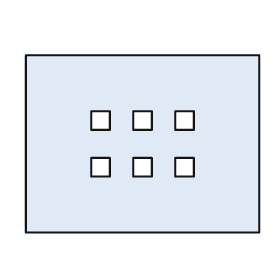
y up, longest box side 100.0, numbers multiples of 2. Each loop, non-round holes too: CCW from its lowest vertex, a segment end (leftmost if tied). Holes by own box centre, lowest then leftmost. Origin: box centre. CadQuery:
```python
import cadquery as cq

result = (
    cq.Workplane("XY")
    .moveTo(-50.0, -38.0)
    .lineTo(50.0, -38.0)
    .lineTo(50.0, 38.0)
    .lineTo(-50.0, 38.0)
    .close()
    .moveTo(-22.0, -14.0)
    .lineTo(-14.0, -14.0)
    .lineTo(-14.0, -6.0)
    .lineTo(-22.0, -6.0)
    .close()
    .moveTo(-4.0, -14.0)
    .lineTo(4.0, -14.0)
    .lineTo(4.0, -6.0)
    .lineTo(-4.0, -6.0)
    .close()
    .moveTo(14.0, -14.0)
    .lineTo(22.0, -14.0)
    .lineTo(22.0, -6.0)
    .lineTo(14.0, -6.0)
    .close()
    .moveTo(-22.0, 6.0)
    .lineTo(-14.0, 6.0)
    .lineTo(-14.0, 14.0)
    .lineTo(-22.0, 14.0)
    .close()
    .moveTo(-4.0, 6.0)
    .lineTo(4.0, 6.0)
    .lineTo(4.0, 14.0)
    .lineTo(-4.0, 14.0)
    .close()
    .moveTo(14.0, 6.0)
    .lineTo(22.0, 6.0)
    .lineTo(22.0, 14.0)
    .lineTo(14.0, 14.0)
    .close()
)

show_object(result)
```